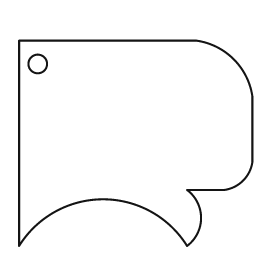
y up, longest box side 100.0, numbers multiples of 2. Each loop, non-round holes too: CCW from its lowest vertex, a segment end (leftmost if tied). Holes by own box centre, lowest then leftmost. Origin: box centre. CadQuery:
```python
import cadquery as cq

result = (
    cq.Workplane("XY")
    .moveTo(-50.0, -44.0)
    .threePointArc((-14.0, -24.0), (22.0, -44.0))
    .threePointArc((28.0, -32.0), (22.0, -20.0))
    .lineTo(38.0, -20.0)
    .threePointArc((46.0, -16.0), (50.0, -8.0))
    .lineTo(50.0, 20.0)
    .threePointArc((42.0, 36.0), (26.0, 44.0))
    .lineTo(-50.0, 44.0)
    .close()
    .moveTo(-42.0, 34.0)
    .circle(4.0)
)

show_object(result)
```